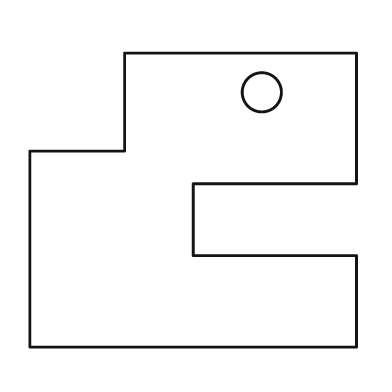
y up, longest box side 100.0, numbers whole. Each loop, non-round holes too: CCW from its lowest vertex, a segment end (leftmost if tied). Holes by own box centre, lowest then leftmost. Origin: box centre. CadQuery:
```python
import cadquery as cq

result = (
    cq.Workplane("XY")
    .moveTo(-50.0, -45.0)
    .lineTo(50.0, -45.0)
    .lineTo(50.0, -17.0)
    .lineTo(0.0, -17.0)
    .lineTo(0.0, 5.0)
    .lineTo(50.0, 5.0)
    .lineTo(50.0, 45.0)
    .lineTo(-21.0, 45.0)
    .lineTo(-21.0, 15.0)
    .lineTo(-50.0, 15.0)
    .close()
    .moveTo(21.0, 33.0)
    .circle(6.0)
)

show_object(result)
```